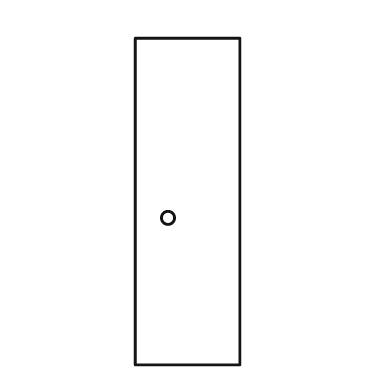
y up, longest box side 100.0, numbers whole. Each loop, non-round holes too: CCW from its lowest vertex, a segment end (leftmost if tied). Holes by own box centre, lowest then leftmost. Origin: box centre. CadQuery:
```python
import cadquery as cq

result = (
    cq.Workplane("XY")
    .moveTo(-16.0, -50.0)
    .lineTo(16.0, -50.0)
    .lineTo(16.0, 50.0)
    .lineTo(-16.0, 50.0)
    .close()
    .moveTo(-6.0, -5.0)
    .circle(2.0)
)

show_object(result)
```